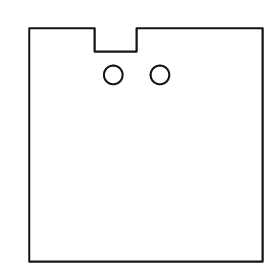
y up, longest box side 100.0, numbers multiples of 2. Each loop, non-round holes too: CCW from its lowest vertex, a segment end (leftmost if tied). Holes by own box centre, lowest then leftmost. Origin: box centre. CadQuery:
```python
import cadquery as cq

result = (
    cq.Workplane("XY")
    .moveTo(-50.0, -50.0)
    .lineTo(50.0, -50.0)
    .lineTo(50.0, 50.0)
    .lineTo(-4.0, 50.0)
    .lineTo(-4.0, 40.0)
    .lineTo(-22.0, 40.0)
    .lineTo(-22.0, 50.0)
    .lineTo(-50.0, 50.0)
    .close()
    .moveTo(-14.0, 30.0)
    .circle(4.0)
    .moveTo(6.0, 30.0)
    .circle(4.0)
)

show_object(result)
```